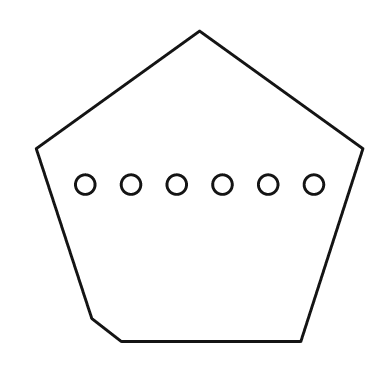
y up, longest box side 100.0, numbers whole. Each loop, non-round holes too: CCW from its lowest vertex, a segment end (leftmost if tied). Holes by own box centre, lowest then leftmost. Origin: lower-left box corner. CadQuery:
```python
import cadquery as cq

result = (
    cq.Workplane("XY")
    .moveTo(26.0, 0.0)
    .lineTo(81.0, 0.0)
    .lineTo(100.0, 59.0)
    .lineTo(50.0, 95.0)
    .lineTo(0.0, 59.0)
    .lineTo(17.0, 7.0)
    .close()
    .moveTo(15.0, 48.0)
    .circle(3.0)
    .moveTo(29.0, 48.0)
    .circle(3.0)
    .moveTo(43.0, 48.0)
    .circle(3.0)
    .moveTo(57.0, 48.0)
    .circle(3.0)
    .moveTo(71.0, 48.0)
    .circle(3.0)
    .moveTo(85.0, 48.0)
    .circle(3.0)
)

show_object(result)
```